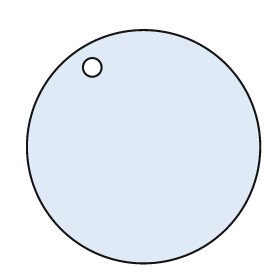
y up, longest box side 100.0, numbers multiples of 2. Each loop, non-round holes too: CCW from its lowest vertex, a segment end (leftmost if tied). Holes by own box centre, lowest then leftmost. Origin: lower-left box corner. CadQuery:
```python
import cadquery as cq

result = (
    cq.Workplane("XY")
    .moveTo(50.0, 50.0)
    .circle(50.0)
    .moveTo(28.0, 84.0)
    .circle(4.0)
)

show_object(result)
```